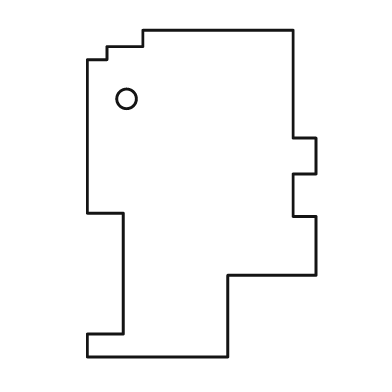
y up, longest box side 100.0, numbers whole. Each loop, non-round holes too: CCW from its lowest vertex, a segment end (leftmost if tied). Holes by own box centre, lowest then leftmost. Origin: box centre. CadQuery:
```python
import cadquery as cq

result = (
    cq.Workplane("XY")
    .moveTo(-35.0, -50.0)
    .lineTo(8.0, -50.0)
    .lineTo(8.0, -25.0)
    .lineTo(35.0, -25.0)
    .lineTo(35.0, -7.0)
    .lineTo(28.0, -7.0)
    .lineTo(28.0, 6.0)
    .lineTo(35.0, 6.0)
    .lineTo(35.0, 17.0)
    .lineTo(28.0, 17.0)
    .lineTo(28.0, 50.0)
    .lineTo(-18.0, 50.0)
    .lineTo(-18.0, 45.0)
    .lineTo(-29.0, 45.0)
    .lineTo(-29.0, 41.0)
    .lineTo(-35.0, 41.0)
    .lineTo(-35.0, -6.0)
    .lineTo(-24.0, -6.0)
    .lineTo(-24.0, -43.0)
    .lineTo(-35.0, -43.0)
    .close()
    .moveTo(-23.0, 29.0)
    .circle(3.0)
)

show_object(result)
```